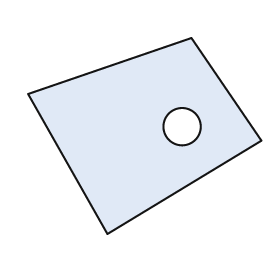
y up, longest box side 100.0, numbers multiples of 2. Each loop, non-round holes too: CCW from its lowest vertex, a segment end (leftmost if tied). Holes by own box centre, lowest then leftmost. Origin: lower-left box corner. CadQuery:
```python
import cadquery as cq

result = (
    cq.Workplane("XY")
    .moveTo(34.0, 0.0)
    .lineTo(100.0, 40.0)
    .lineTo(70.0, 84.0)
    .lineTo(0.0, 60.0)
    .close()
    .moveTo(66.0, 46.0)
    .circle(8.0)
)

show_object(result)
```